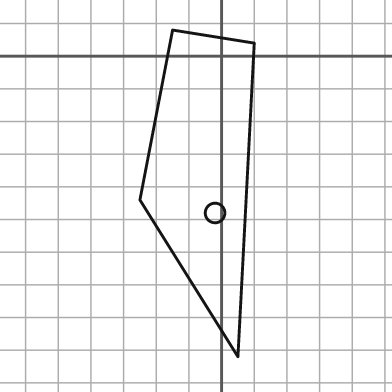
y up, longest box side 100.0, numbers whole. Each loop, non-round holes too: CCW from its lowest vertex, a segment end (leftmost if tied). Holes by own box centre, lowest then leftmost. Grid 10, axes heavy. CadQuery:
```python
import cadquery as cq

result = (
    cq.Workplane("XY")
    .moveTo(5.0, -92.0)
    .lineTo(10.0, 4.0)
    .lineTo(-15.0, 8.0)
    .lineTo(-25.0, -44.0)
    .close()
    .moveTo(-2.0, -48.0)
    .circle(3.0)
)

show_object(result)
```